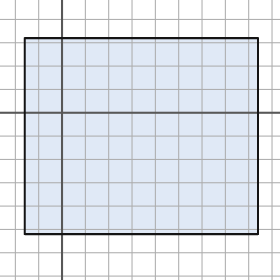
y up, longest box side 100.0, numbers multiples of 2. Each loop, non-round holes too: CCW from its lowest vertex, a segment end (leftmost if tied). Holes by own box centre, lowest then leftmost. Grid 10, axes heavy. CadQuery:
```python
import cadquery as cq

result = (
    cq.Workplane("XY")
    .moveTo(-16.0, -52.0)
    .lineTo(84.0, -52.0)
    .lineTo(84.0, 32.0)
    .lineTo(-16.0, 32.0)
    .close()
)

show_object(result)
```